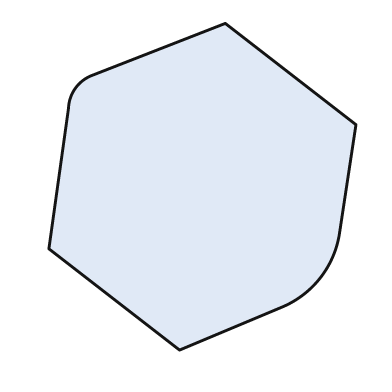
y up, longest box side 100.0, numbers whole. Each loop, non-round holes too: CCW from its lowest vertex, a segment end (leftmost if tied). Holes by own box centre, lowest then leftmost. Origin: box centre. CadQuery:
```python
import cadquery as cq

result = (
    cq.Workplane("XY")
    .moveTo(-7.0, -50.0)
    .lineTo(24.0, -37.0)
    .threePointArc((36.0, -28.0), (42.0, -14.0))
    .lineTo(47.0, 19.0)
    .lineTo(7.0, 50.0)
    .lineTo(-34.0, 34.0)
    .threePointArc((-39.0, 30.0), (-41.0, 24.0))
    .lineTo(-47.0, -19.0)
    .close()
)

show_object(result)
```